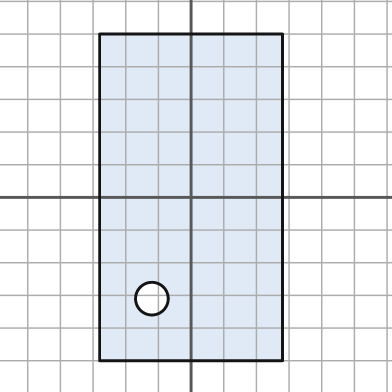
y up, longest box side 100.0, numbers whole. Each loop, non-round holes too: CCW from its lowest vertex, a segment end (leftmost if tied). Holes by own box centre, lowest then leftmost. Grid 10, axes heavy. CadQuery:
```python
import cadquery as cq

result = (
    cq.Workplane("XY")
    .moveTo(-28.0, -50.0)
    .lineTo(28.0, -50.0)
    .lineTo(28.0, 50.0)
    .lineTo(-28.0, 50.0)
    .close()
    .moveTo(-12.0, -31.0)
    .circle(5.0)
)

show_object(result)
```